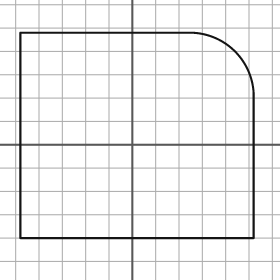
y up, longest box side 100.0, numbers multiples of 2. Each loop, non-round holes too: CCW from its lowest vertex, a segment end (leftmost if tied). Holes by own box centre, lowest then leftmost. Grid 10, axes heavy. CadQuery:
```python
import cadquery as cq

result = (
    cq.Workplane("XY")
    .moveTo(-48.0, -40.0)
    .lineTo(52.0, -40.0)
    .lineTo(52.0, 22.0)
    .threePointArc((44.0, 40.0), (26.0, 48.0))
    .lineTo(-48.0, 48.0)
    .close()
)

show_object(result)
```